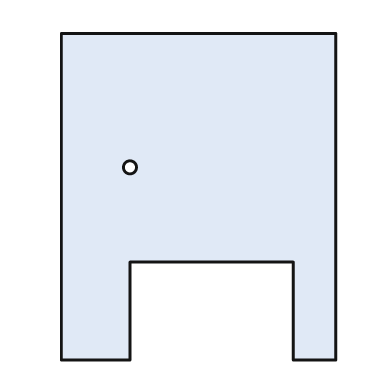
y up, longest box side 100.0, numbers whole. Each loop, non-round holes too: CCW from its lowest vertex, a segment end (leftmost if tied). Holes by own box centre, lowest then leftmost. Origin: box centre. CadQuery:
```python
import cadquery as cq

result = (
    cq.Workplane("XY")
    .moveTo(-42.0, -50.0)
    .lineTo(-21.0, -50.0)
    .lineTo(-21.0, -20.0)
    .lineTo(29.0, -20.0)
    .lineTo(29.0, -50.0)
    .lineTo(42.0, -50.0)
    .lineTo(42.0, 50.0)
    .lineTo(-42.0, 50.0)
    .close()
    .moveTo(-21.0, 9.0)
    .circle(2.0)
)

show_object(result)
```